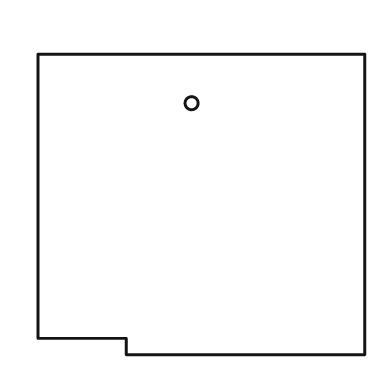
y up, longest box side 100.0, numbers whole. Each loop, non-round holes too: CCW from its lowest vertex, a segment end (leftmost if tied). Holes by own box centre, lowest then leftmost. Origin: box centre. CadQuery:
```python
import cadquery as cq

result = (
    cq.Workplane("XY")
    .moveTo(-23.0, -46.0)
    .lineTo(50.0, -46.0)
    .lineTo(50.0, 46.0)
    .lineTo(-50.0, 46.0)
    .lineTo(-50.0, -41.0)
    .lineTo(-23.0, -41.0)
    .close()
    .moveTo(-3.0, 31.0)
    .circle(2.0)
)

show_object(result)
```